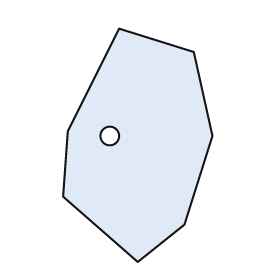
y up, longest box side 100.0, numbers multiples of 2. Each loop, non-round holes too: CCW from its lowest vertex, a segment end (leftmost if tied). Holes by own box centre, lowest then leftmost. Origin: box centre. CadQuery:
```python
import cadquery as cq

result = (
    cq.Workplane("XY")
    .moveTo(0.0, -50.0)
    .lineTo(20.0, -34.0)
    .lineTo(32.0, 4.0)
    .lineTo(24.0, 40.0)
    .lineTo(-8.0, 50.0)
    .lineTo(-30.0, 6.0)
    .lineTo(-32.0, -22.0)
    .close()
    .moveTo(-12.0, 4.0)
    .circle(4.0)
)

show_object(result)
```